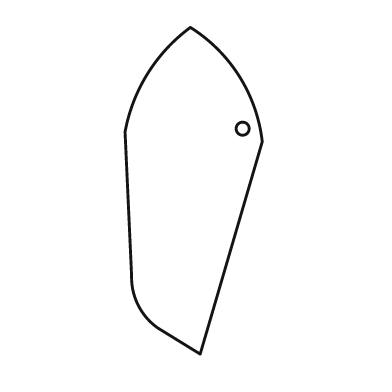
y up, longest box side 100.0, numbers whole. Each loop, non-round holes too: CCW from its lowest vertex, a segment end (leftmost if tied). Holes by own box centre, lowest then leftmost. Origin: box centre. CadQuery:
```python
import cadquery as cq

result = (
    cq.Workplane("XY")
    .moveTo(2.0, -50.0)
    .lineTo(21.0, 15.0)
    .threePointArc((14.0, 35.0), (-1.0, 50.0))
    .threePointArc((-14.0, 36.0), (-21.0, 18.0))
    .lineTo(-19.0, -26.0)
    .threePointArc((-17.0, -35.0), (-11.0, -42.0))
    .close()
    .moveTo(15.0, 19.0)
    .circle(2.0)
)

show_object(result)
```